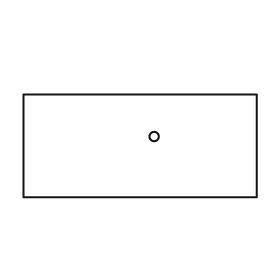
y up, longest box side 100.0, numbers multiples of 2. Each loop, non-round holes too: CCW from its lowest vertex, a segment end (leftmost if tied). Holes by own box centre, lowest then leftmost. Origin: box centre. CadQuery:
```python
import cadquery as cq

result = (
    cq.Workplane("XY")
    .moveTo(-50.0, -22.0)
    .lineTo(50.0, -22.0)
    .lineTo(50.0, 22.0)
    .lineTo(-50.0, 22.0)
    .close()
    .moveTo(6.0, 4.0)
    .circle(2.0)
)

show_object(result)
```